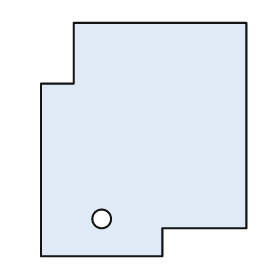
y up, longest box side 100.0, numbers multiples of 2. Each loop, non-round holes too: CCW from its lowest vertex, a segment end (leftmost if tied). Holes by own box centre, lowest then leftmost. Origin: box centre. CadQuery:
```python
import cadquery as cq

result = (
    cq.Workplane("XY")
    .moveTo(-44.0, -50.0)
    .lineTo(8.0, -50.0)
    .lineTo(8.0, -38.0)
    .lineTo(44.0, -38.0)
    .lineTo(44.0, 50.0)
    .lineTo(-30.0, 50.0)
    .lineTo(-30.0, 24.0)
    .lineTo(-44.0, 24.0)
    .close()
    .moveTo(-18.0, -34.0)
    .circle(4.0)
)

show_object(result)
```